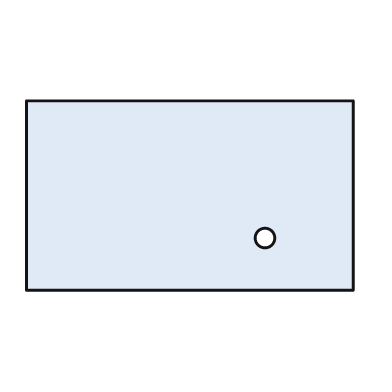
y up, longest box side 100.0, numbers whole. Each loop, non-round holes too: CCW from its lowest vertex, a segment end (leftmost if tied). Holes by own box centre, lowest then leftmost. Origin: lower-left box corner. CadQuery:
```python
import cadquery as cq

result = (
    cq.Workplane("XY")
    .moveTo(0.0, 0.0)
    .lineTo(100.0, 0.0)
    .lineTo(100.0, 58.0)
    .lineTo(0.0, 58.0)
    .close()
    .moveTo(73.0, 16.0)
    .circle(3.0)
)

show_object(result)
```